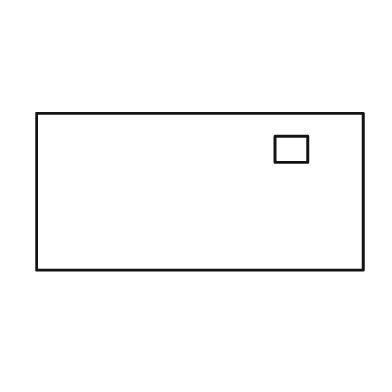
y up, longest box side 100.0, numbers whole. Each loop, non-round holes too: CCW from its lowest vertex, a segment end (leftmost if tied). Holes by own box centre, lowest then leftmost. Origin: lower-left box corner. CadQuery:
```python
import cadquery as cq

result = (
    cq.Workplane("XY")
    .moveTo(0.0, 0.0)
    .lineTo(100.0, 0.0)
    .lineTo(100.0, 48.0)
    .lineTo(0.0, 48.0)
    .close()
    .moveTo(73.0, 33.0)
    .lineTo(83.0, 33.0)
    .lineTo(83.0, 41.0)
    .lineTo(73.0, 41.0)
    .close()
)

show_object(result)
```